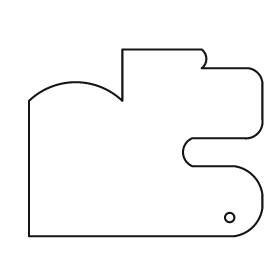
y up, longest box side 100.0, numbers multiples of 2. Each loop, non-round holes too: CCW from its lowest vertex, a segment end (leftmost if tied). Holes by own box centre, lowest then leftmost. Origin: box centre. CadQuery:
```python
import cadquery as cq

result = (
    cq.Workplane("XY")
    .moveTo(-50.0, -40.0)
    .lineTo(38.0, -40.0)
    .threePointArc((46.0, -36.0), (50.0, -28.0))
    .lineTo(50.0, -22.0)
    .threePointArc((46.0, -14.0), (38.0, -10.0))
    .lineTo(20.0, -10.0)
    .threePointArc((16.0, -4.0), (20.0, 2.0))
    .lineTo(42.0, 2.0)
    .threePointArc((48.0, 4.0), (50.0, 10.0))
    .lineTo(50.0, 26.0)
    .threePointArc((48.0, 30.0), (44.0, 32.0))
    .lineTo(24.0, 32.0)
    .threePointArc((26.0, 36.0), (24.0, 40.0))
    .lineTo(-10.0, 40.0)
    .lineTo(-10.0, 18.0)
    .threePointArc((-30.0, 26.0), (-50.0, 18.0))
    .close()
    .moveTo(36.0, -32.0)
    .circle(2.0)
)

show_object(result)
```